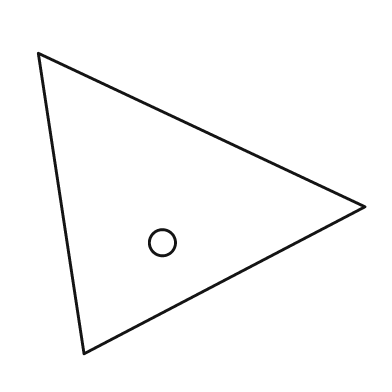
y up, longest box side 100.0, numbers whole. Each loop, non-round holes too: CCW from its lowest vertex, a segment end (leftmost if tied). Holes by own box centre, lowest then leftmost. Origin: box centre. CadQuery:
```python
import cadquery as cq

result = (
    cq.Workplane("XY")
    .moveTo(-36.0, -46.0)
    .lineTo(50.0, -1.0)
    .lineTo(-50.0, 46.0)
    .close()
    .moveTo(-12.0, -12.0)
    .circle(4.0)
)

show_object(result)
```